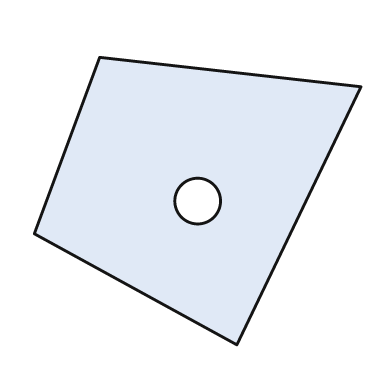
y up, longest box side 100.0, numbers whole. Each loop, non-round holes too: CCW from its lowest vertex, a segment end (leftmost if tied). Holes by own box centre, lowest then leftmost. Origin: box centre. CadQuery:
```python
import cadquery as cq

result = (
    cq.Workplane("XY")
    .moveTo(12.0, -44.0)
    .lineTo(50.0, 35.0)
    .lineTo(-30.0, 44.0)
    .lineTo(-50.0, -10.0)
    .close()
    .moveTo(0.0, 0.0)
    .circle(7.0)
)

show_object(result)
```